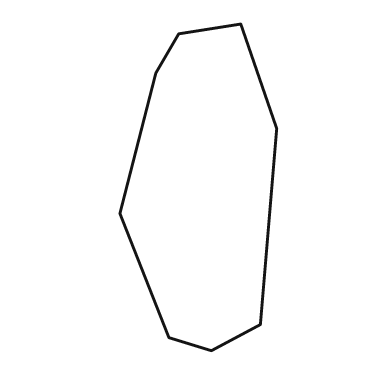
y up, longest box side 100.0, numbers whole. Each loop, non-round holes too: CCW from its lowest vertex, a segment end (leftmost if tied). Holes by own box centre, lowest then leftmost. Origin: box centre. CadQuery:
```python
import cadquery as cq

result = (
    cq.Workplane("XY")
    .moveTo(4.0, -50.0)
    .lineTo(19.0, -42.0)
    .lineTo(24.0, 18.0)
    .lineTo(13.0, 50.0)
    .lineTo(-6.0, 47.0)
    .lineTo(-13.0, 35.0)
    .lineTo(-24.0, -8.0)
    .lineTo(-9.0, -46.0)
    .close()
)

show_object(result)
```